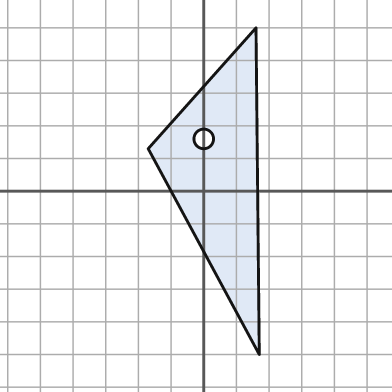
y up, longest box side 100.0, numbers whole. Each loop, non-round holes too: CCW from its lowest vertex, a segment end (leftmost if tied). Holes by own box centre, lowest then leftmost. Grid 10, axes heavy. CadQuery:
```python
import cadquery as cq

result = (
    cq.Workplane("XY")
    .moveTo(17.0, -50.0)
    .lineTo(16.0, 50.0)
    .lineTo(-17.0, 13.0)
    .close()
    .moveTo(0.0, 16.0)
    .circle(3.0)
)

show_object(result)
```